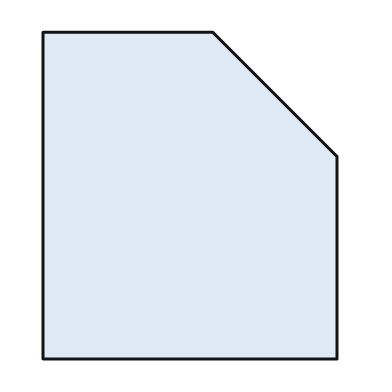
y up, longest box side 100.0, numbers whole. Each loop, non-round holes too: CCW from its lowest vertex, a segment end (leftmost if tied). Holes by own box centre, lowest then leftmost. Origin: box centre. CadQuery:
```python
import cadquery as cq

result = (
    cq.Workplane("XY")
    .moveTo(-45.0, -50.0)
    .lineTo(45.0, -50.0)
    .lineTo(45.0, 12.0)
    .lineTo(7.0, 50.0)
    .lineTo(-45.0, 50.0)
    .close()
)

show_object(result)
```